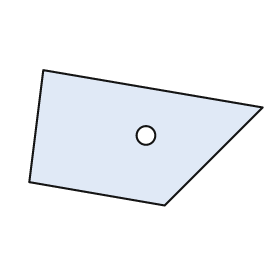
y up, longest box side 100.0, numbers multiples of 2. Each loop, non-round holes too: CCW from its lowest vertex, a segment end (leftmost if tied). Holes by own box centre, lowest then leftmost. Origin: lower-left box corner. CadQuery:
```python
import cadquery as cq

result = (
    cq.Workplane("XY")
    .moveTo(58.0, 0.0)
    .lineTo(100.0, 42.0)
    .lineTo(6.0, 58.0)
    .lineTo(0.0, 10.0)
    .close()
    .moveTo(50.0, 30.0)
    .circle(4.0)
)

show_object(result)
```